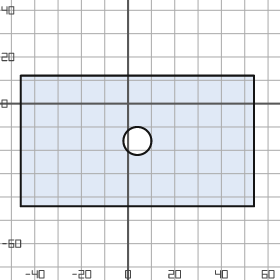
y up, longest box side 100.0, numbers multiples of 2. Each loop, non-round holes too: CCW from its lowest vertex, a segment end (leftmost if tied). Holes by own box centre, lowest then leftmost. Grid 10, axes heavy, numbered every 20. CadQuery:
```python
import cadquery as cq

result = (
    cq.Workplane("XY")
    .moveTo(-46.0, -44.0)
    .lineTo(54.0, -44.0)
    .lineTo(54.0, 12.0)
    .lineTo(-46.0, 12.0)
    .close()
    .moveTo(4.0, -16.0)
    .circle(6.0)
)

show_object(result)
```